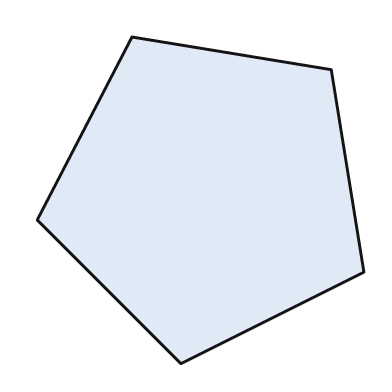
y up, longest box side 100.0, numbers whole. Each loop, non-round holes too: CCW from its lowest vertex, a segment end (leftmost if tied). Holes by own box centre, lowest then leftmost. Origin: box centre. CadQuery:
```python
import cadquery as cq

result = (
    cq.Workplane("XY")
    .moveTo(-6.0, -50.0)
    .lineTo(50.0, -22.0)
    .lineTo(40.0, 40.0)
    .lineTo(-21.0, 50.0)
    .lineTo(-50.0, -6.0)
    .close()
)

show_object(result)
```